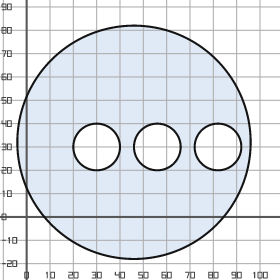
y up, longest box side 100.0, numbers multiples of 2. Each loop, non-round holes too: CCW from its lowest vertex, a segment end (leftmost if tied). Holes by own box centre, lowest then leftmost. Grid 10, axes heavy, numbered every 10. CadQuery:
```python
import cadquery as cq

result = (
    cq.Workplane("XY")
    .moveTo(46.0, 32.0)
    .circle(50.0)
    .moveTo(30.0, 30.0)
    .circle(10.0)
    .moveTo(56.0, 30.0)
    .circle(10.0)
    .moveTo(82.0, 30.0)
    .circle(10.0)
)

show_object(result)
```